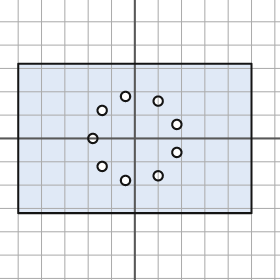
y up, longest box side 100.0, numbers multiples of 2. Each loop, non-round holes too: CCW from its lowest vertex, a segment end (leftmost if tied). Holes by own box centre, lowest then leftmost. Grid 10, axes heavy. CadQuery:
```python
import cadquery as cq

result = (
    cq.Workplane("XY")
    .moveTo(-50.0, -32.0)
    .lineTo(50.0, -32.0)
    .lineTo(50.0, 32.0)
    .lineTo(-50.0, 32.0)
    .close()
    .moveTo(-4.0, -18.0)
    .circle(2.0)
    .moveTo(10.0, -16.0)
    .circle(2.0)
    .moveTo(-14.0, -12.0)
    .circle(2.0)
    .moveTo(18.0, -6.0)
    .circle(2.0)
    .moveTo(-18.0, 0.0)
    .circle(2.0)
    .moveTo(18.0, 6.0)
    .circle(2.0)
    .moveTo(-14.0, 12.0)
    .circle(2.0)
    .moveTo(10.0, 16.0)
    .circle(2.0)
    .moveTo(-4.0, 18.0)
    .circle(2.0)
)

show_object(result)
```